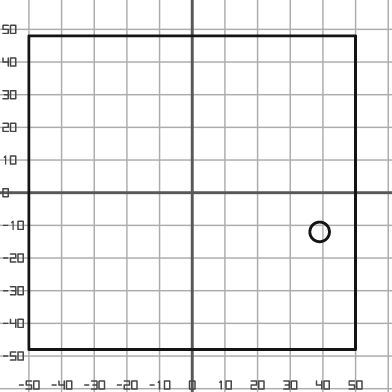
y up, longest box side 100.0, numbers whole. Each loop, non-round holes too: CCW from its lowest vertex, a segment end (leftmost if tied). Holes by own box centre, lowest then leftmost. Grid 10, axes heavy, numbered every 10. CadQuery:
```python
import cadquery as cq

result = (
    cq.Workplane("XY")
    .moveTo(-50.0, -48.0)
    .lineTo(50.0, -48.0)
    .lineTo(50.0, 48.0)
    .lineTo(-50.0, 48.0)
    .close()
    .moveTo(39.0, -12.0)
    .circle(3.0)
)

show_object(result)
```